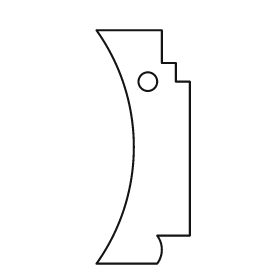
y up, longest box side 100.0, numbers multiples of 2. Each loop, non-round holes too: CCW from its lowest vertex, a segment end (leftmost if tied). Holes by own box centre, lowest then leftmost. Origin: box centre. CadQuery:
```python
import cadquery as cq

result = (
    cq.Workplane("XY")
    .moveTo(-20.0, -50.0)
    .lineTo(6.0, -50.0)
    .threePointArc((8.0, -44.0), (6.0, -38.0))
    .lineTo(20.0, -38.0)
    .lineTo(20.0, 28.0)
    .lineTo(14.0, 28.0)
    .lineTo(14.0, 36.0)
    .lineTo(8.0, 36.0)
    .lineTo(8.0, 50.0)
    .lineTo(-20.0, 50.0)
    .threePointArc((-4.0, 0.0), (-20.0, -50.0))
    .close()
    .moveTo(2.0, 28.0)
    .circle(4.0)
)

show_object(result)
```